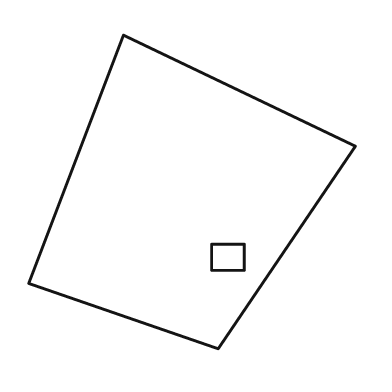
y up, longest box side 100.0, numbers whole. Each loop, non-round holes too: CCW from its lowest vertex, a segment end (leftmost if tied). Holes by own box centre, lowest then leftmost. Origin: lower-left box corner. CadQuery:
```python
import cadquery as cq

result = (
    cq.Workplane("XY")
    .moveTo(58.0, 0.0)
    .lineTo(100.0, 62.0)
    .lineTo(29.0, 96.0)
    .lineTo(0.0, 20.0)
    .close()
    .moveTo(56.0, 24.0)
    .lineTo(66.0, 24.0)
    .lineTo(66.0, 32.0)
    .lineTo(56.0, 32.0)
    .close()
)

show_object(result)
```